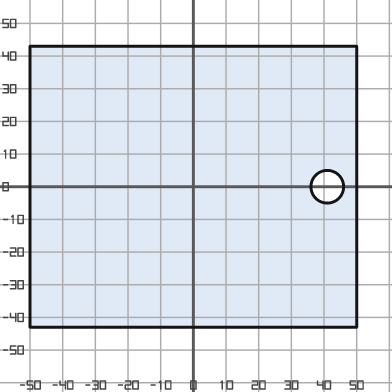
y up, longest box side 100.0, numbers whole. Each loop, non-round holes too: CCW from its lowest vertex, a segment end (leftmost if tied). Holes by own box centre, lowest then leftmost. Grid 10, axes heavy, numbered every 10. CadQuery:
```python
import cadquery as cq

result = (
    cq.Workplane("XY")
    .moveTo(-50.0, -43.0)
    .lineTo(50.0, -43.0)
    .lineTo(50.0, 43.0)
    .lineTo(-50.0, 43.0)
    .close()
    .moveTo(41.0, 0.0)
    .circle(5.0)
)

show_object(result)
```